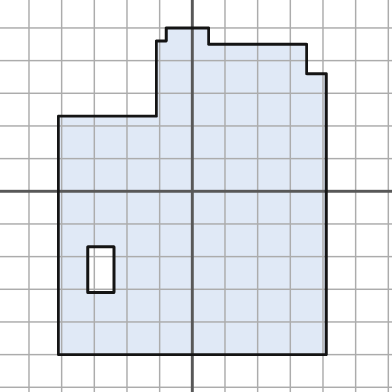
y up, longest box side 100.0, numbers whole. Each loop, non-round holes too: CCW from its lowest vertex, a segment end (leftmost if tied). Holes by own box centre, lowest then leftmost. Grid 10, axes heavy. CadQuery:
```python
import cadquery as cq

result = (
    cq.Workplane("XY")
    .moveTo(-41.0, -50.0)
    .lineTo(41.0, -50.0)
    .lineTo(41.0, 36.0)
    .lineTo(35.0, 36.0)
    .lineTo(35.0, 45.0)
    .lineTo(5.0, 45.0)
    .lineTo(5.0, 50.0)
    .lineTo(-8.0, 50.0)
    .lineTo(-8.0, 46.0)
    .lineTo(-11.0, 46.0)
    .lineTo(-11.0, 23.0)
    .lineTo(-41.0, 23.0)
    .close()
    .moveTo(-32.0, -31.0)
    .lineTo(-24.0, -31.0)
    .lineTo(-24.0, -17.0)
    .lineTo(-32.0, -17.0)
    .close()
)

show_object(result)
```